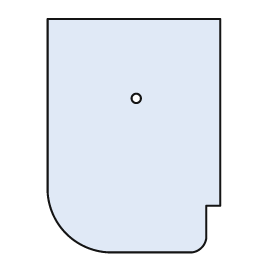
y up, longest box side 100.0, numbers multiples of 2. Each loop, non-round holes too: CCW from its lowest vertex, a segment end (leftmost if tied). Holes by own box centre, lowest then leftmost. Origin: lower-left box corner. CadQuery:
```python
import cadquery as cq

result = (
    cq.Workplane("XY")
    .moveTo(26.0, 0.0)
    .lineTo(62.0, 0.0)
    .threePointArc((66.0, 2.0), (68.0, 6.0))
    .lineTo(68.0, 20.0)
    .lineTo(74.0, 20.0)
    .lineTo(74.0, 100.0)
    .lineTo(0.0, 100.0)
    .lineTo(0.0, 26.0)
    .threePointArc((8.0, 8.0), (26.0, 0.0))
    .close()
    .moveTo(38.0, 66.0)
    .circle(2.0)
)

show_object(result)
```